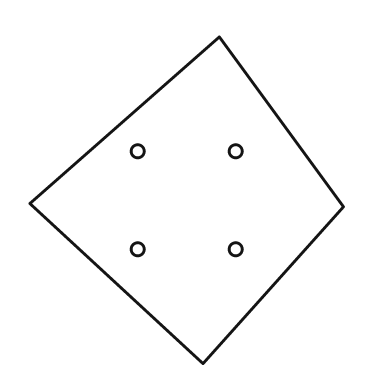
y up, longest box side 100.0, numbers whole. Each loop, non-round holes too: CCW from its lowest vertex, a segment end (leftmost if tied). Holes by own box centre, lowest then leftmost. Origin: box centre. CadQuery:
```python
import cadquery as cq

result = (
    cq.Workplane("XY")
    .moveTo(5.0, -50.0)
    .lineTo(48.0, -2.0)
    .lineTo(10.0, 50.0)
    .lineTo(-48.0, -1.0)
    .close()
    .moveTo(-15.0, -15.0)
    .circle(2.0)
    .moveTo(15.0, -15.0)
    .circle(2.0)
    .moveTo(-15.0, 15.0)
    .circle(2.0)
    .moveTo(15.0, 15.0)
    .circle(2.0)
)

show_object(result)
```